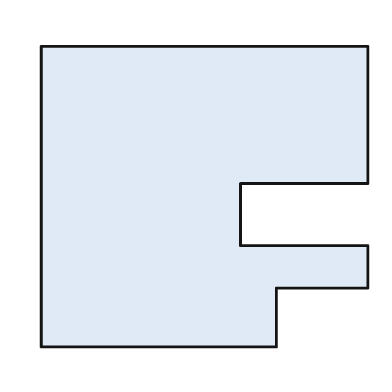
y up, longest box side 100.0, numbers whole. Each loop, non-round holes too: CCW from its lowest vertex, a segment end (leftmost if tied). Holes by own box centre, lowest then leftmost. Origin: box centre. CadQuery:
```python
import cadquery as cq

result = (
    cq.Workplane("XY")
    .moveTo(-50.0, -46.0)
    .lineTo(22.0, -46.0)
    .lineTo(22.0, -28.0)
    .lineTo(50.0, -28.0)
    .lineTo(50.0, -15.0)
    .lineTo(11.0, -15.0)
    .lineTo(11.0, 4.0)
    .lineTo(50.0, 4.0)
    .lineTo(50.0, 46.0)
    .lineTo(-50.0, 46.0)
    .close()
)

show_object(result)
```